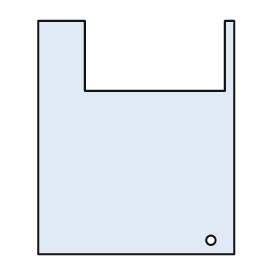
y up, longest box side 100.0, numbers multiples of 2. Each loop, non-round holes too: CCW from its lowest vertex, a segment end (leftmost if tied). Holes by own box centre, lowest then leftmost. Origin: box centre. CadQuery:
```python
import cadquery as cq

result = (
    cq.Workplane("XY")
    .moveTo(-42.0, -50.0)
    .lineTo(42.0, -50.0)
    .lineTo(42.0, 50.0)
    .lineTo(38.0, 50.0)
    .lineTo(38.0, 20.0)
    .lineTo(-22.0, 20.0)
    .lineTo(-22.0, 50.0)
    .lineTo(-42.0, 50.0)
    .close()
    .moveTo(32.0, -44.0)
    .circle(2.0)
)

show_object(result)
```